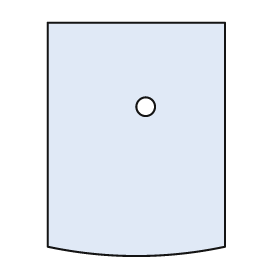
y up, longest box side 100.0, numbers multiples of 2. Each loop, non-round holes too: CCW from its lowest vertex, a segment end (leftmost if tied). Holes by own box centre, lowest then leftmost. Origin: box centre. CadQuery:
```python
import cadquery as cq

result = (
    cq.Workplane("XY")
    .moveTo(-38.0, -46.0)
    .threePointArc((0.0, -50.0), (38.0, -46.0))
    .lineTo(38.0, 50.0)
    .lineTo(-38.0, 50.0)
    .close()
    .moveTo(4.0, 14.0)
    .circle(4.0)
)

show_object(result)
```